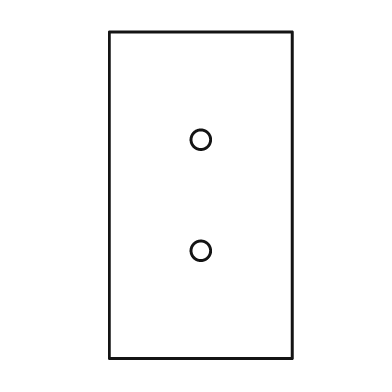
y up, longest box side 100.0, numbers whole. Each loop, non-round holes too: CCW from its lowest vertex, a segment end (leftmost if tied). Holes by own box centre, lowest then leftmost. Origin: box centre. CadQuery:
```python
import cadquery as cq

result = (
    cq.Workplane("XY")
    .moveTo(-28.0, -50.0)
    .lineTo(28.0, -50.0)
    .lineTo(28.0, 50.0)
    .lineTo(-28.0, 50.0)
    .close()
    .moveTo(0.0, -17.0)
    .circle(3.0)
    .moveTo(0.0, 17.0)
    .circle(3.0)
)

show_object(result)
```